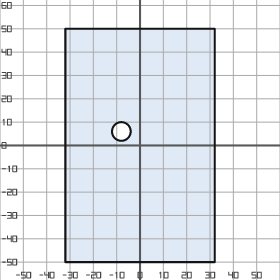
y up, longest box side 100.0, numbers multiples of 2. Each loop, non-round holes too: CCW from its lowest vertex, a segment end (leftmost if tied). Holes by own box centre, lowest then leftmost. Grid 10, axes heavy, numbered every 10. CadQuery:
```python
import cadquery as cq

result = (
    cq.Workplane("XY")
    .moveTo(-32.0, -50.0)
    .lineTo(32.0, -50.0)
    .lineTo(32.0, 50.0)
    .lineTo(-32.0, 50.0)
    .close()
    .moveTo(-8.0, 6.0)
    .circle(4.0)
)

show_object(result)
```